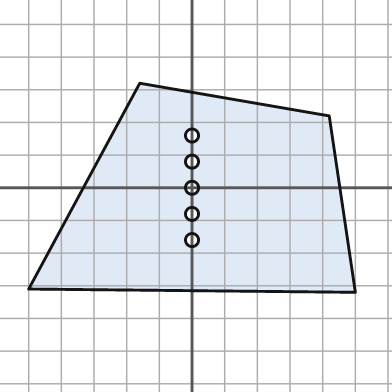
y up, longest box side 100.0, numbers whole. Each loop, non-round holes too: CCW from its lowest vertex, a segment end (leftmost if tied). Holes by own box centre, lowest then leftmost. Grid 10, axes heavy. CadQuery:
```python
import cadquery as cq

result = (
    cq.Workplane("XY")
    .moveTo(50.0, -32.0)
    .lineTo(42.0, 22.0)
    .lineTo(-16.0, 32.0)
    .lineTo(-50.0, -31.0)
    .close()
    .moveTo(0.0, -16.0)
    .circle(2.0)
    .moveTo(0.0, -8.0)
    .circle(2.0)
    .moveTo(0.0, 0.0)
    .circle(2.0)
    .moveTo(0.0, 8.0)
    .circle(2.0)
    .moveTo(0.0, 16.0)
    .circle(2.0)
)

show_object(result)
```